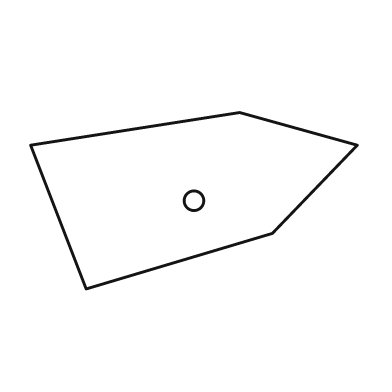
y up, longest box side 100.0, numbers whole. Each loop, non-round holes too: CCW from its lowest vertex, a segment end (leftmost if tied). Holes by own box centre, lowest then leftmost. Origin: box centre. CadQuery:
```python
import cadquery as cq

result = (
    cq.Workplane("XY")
    .moveTo(-33.0, -27.0)
    .lineTo(24.0, -10.0)
    .lineTo(50.0, 17.0)
    .lineTo(14.0, 27.0)
    .lineTo(-50.0, 17.0)
    .close()
    .moveTo(0.0, 0.0)
    .circle(3.0)
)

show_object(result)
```